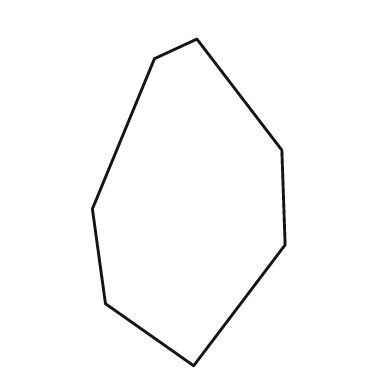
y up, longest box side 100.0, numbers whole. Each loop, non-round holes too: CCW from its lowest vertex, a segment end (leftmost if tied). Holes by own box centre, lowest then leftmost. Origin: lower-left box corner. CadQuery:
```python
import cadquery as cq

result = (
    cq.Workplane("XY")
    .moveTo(31.0, 0.0)
    .lineTo(59.0, 37.0)
    .lineTo(58.0, 66.0)
    .lineTo(32.0, 100.0)
    .lineTo(19.0, 94.0)
    .lineTo(0.0, 48.0)
    .lineTo(4.0, 19.0)
    .close()
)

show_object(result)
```